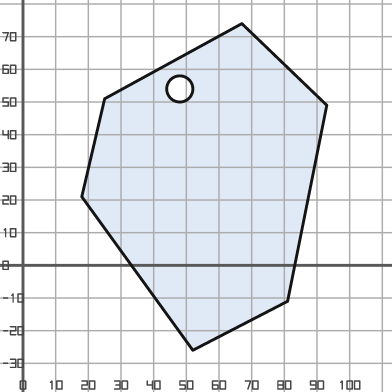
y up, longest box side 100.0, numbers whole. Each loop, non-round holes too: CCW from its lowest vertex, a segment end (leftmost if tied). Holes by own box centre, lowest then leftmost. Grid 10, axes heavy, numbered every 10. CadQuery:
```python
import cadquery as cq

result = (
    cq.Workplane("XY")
    .moveTo(52.0, -26.0)
    .lineTo(81.0, -11.0)
    .lineTo(93.0, 49.0)
    .lineTo(67.0, 74.0)
    .lineTo(25.0, 51.0)
    .lineTo(18.0, 21.0)
    .close()
    .moveTo(48.0, 54.0)
    .circle(4.0)
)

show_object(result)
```